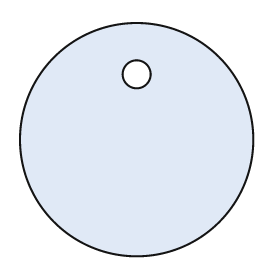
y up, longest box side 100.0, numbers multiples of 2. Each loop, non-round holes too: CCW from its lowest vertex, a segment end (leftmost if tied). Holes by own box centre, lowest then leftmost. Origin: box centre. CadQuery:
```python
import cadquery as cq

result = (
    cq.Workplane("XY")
    .moveTo(0.0, 0.0)
    .circle(50.0)
    .moveTo(0.0, 28.0)
    .circle(6.0)
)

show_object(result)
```